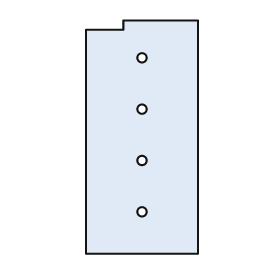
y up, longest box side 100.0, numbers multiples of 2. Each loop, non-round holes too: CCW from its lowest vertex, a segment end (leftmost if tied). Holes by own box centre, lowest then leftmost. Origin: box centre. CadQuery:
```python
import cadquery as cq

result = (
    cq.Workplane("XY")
    .moveTo(-24.0, -50.0)
    .lineTo(24.0, -50.0)
    .lineTo(24.0, 50.0)
    .lineTo(-8.0, 50.0)
    .lineTo(-8.0, 46.0)
    .lineTo(-24.0, 46.0)
    .close()
    .moveTo(0.0, -32.0)
    .circle(2.0)
    .moveTo(0.0, -10.0)
    .circle(2.0)
    .moveTo(0.0, 12.0)
    .circle(2.0)
    .moveTo(0.0, 34.0)
    .circle(2.0)
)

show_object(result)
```